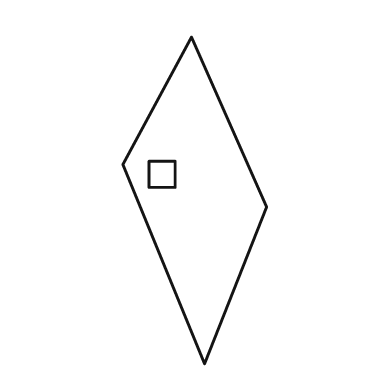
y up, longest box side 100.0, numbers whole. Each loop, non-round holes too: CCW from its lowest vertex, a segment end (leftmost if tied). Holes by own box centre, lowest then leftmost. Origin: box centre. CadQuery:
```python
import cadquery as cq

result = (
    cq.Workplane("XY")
    .moveTo(3.0, -50.0)
    .lineTo(22.0, -2.0)
    .lineTo(-1.0, 50.0)
    .lineTo(-22.0, 11.0)
    .close()
    .moveTo(-14.0, 4.0)
    .lineTo(-6.0, 4.0)
    .lineTo(-6.0, 12.0)
    .lineTo(-14.0, 12.0)
    .close()
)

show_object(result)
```